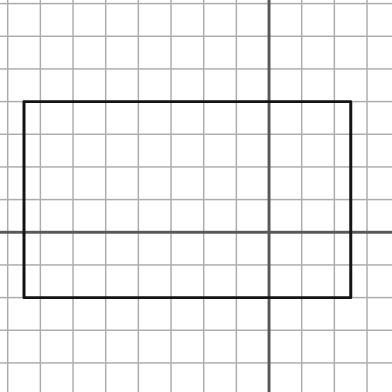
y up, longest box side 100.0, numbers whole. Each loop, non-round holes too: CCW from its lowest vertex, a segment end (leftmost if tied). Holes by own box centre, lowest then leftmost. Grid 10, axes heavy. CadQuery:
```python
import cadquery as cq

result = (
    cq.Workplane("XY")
    .moveTo(-75.0, -20.0)
    .lineTo(25.0, -20.0)
    .lineTo(25.0, 40.0)
    .lineTo(-75.0, 40.0)
    .close()
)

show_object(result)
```